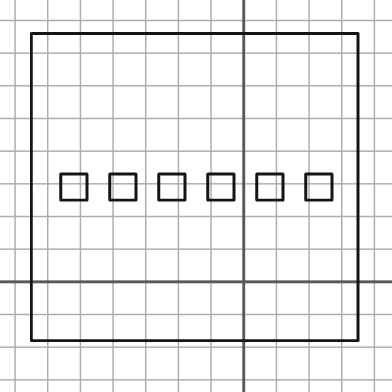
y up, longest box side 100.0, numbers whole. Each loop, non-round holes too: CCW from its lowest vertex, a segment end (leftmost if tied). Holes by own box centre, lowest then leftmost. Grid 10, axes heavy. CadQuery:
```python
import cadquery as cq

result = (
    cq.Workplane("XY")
    .moveTo(-65.0, -18.0)
    .lineTo(35.0, -18.0)
    .lineTo(35.0, 76.0)
    .lineTo(-65.0, 76.0)
    .close()
    .moveTo(-56.0, 25.0)
    .lineTo(-48.0, 25.0)
    .lineTo(-48.0, 33.0)
    .lineTo(-56.0, 33.0)
    .close()
    .moveTo(-41.0, 25.0)
    .lineTo(-33.0, 25.0)
    .lineTo(-33.0, 33.0)
    .lineTo(-41.0, 33.0)
    .close()
    .moveTo(-26.0, 25.0)
    .lineTo(-18.0, 25.0)
    .lineTo(-18.0, 33.0)
    .lineTo(-26.0, 33.0)
    .close()
    .moveTo(-11.0, 25.0)
    .lineTo(-3.0, 25.0)
    .lineTo(-3.0, 33.0)
    .lineTo(-11.0, 33.0)
    .close()
    .moveTo(4.0, 25.0)
    .lineTo(12.0, 25.0)
    .lineTo(12.0, 33.0)
    .lineTo(4.0, 33.0)
    .close()
    .moveTo(19.0, 25.0)
    .lineTo(27.0, 25.0)
    .lineTo(27.0, 33.0)
    .lineTo(19.0, 33.0)
    .close()
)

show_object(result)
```